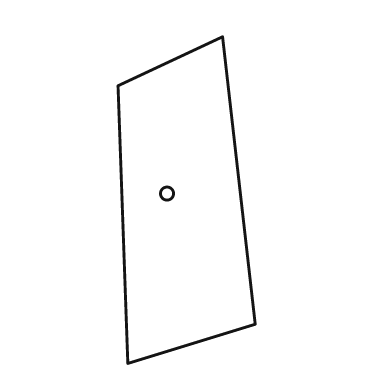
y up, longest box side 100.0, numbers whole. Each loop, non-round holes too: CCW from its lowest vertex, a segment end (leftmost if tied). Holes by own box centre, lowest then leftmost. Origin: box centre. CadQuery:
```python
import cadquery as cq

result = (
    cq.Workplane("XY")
    .moveTo(-18.0, -50.0)
    .lineTo(21.0, -38.0)
    .lineTo(11.0, 50.0)
    .lineTo(-21.0, 35.0)
    .close()
    .moveTo(-6.0, 2.0)
    .circle(2.0)
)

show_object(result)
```